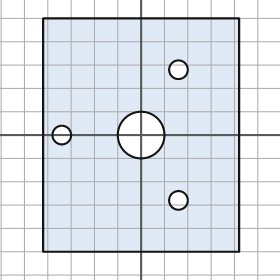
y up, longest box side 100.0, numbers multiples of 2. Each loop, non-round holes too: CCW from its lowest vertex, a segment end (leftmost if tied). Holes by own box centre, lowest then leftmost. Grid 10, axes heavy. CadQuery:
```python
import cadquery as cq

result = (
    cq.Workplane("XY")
    .moveTo(-42.0, -50.0)
    .lineTo(42.0, -50.0)
    .lineTo(42.0, 50.0)
    .lineTo(-42.0, 50.0)
    .close()
    .moveTo(16.0, -28.0)
    .circle(4.0)
    .moveTo(-34.0, 0.0)
    .circle(4.0)
    .moveTo(0.0, 0.0)
    .circle(10.0)
    .moveTo(16.0, 28.0)
    .circle(4.0)
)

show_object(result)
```